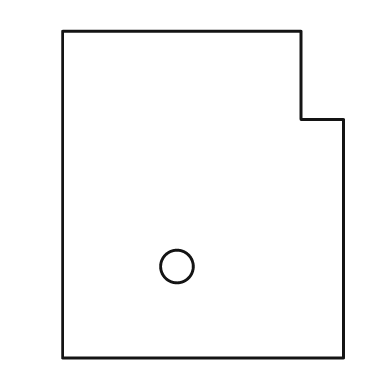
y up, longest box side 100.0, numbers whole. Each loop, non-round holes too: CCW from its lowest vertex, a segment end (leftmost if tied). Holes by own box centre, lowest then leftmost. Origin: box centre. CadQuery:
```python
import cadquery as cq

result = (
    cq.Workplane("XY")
    .moveTo(-43.0, -50.0)
    .lineTo(43.0, -50.0)
    .lineTo(43.0, 23.0)
    .lineTo(30.0, 23.0)
    .lineTo(30.0, 50.0)
    .lineTo(-43.0, 50.0)
    .close()
    .moveTo(-8.0, -22.0)
    .circle(5.0)
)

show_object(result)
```